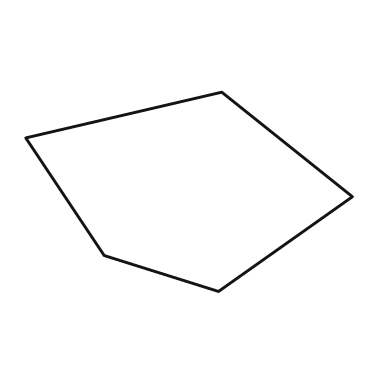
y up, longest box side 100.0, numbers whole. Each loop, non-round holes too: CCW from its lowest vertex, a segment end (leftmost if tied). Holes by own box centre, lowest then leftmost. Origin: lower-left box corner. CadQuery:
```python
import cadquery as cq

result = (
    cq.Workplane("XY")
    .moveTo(59.0, 0.0)
    .lineTo(100.0, 29.0)
    .lineTo(60.0, 61.0)
    .lineTo(0.0, 47.0)
    .lineTo(24.0, 11.0)
    .close()
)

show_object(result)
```